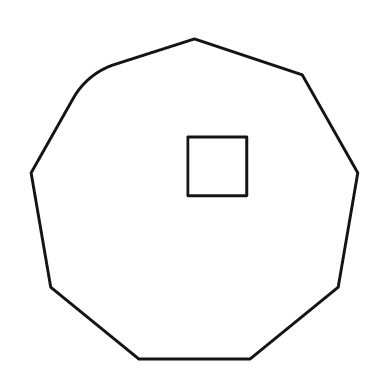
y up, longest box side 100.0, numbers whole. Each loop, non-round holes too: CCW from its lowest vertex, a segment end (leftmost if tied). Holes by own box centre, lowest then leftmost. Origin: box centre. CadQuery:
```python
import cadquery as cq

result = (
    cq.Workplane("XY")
    .moveTo(-17.0, -49.0)
    .lineTo(17.0, -49.0)
    .lineTo(44.0, -27.0)
    .lineTo(50.0, 8.0)
    .lineTo(33.0, 38.0)
    .lineTo(0.0, 49.0)
    .lineTo(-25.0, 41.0)
    .threePointArc((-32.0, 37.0), (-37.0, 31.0))
    .lineTo(-50.0, 8.0)
    .lineTo(-44.0, -27.0)
    .close()
    .moveTo(-2.0, 1.0)
    .lineTo(16.0, 1.0)
    .lineTo(16.0, 19.0)
    .lineTo(-2.0, 19.0)
    .close()
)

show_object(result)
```